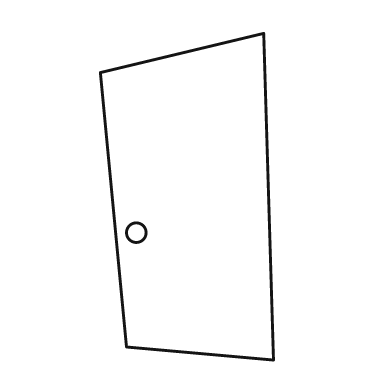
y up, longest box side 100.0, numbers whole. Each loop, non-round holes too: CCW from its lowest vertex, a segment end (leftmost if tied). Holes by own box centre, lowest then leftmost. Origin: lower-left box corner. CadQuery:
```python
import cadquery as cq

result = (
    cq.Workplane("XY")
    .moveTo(53.0, 0.0)
    .lineTo(50.0, 100.0)
    .lineTo(0.0, 88.0)
    .lineTo(8.0, 4.0)
    .close()
    .moveTo(11.0, 39.0)
    .circle(3.0)
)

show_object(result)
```